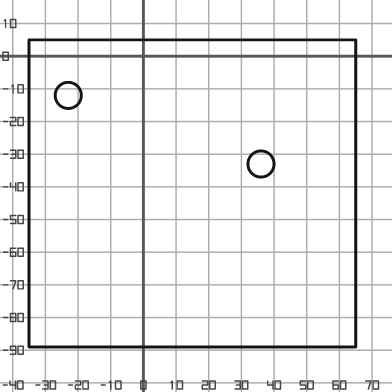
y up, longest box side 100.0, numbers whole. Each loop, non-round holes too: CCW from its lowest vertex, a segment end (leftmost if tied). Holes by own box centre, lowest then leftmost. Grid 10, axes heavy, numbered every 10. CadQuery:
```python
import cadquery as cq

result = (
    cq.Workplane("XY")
    .moveTo(-35.0, -89.0)
    .lineTo(65.0, -89.0)
    .lineTo(65.0, 5.0)
    .lineTo(-35.0, 5.0)
    .close()
    .moveTo(36.0, -33.0)
    .circle(4.0)
    .moveTo(-23.0, -12.0)
    .circle(4.0)
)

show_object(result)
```